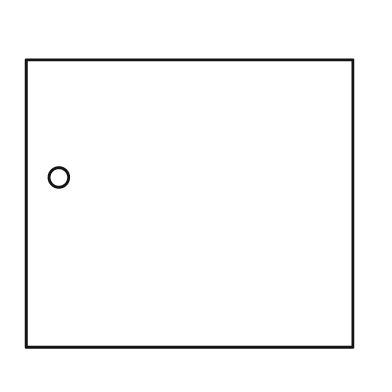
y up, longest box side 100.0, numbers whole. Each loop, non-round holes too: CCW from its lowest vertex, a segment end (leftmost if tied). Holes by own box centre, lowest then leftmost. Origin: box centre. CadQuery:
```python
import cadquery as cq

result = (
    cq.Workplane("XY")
    .moveTo(-50.0, -44.0)
    .lineTo(50.0, -44.0)
    .lineTo(50.0, 44.0)
    .lineTo(-50.0, 44.0)
    .close()
    .moveTo(-40.0, 8.0)
    .circle(3.0)
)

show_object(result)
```